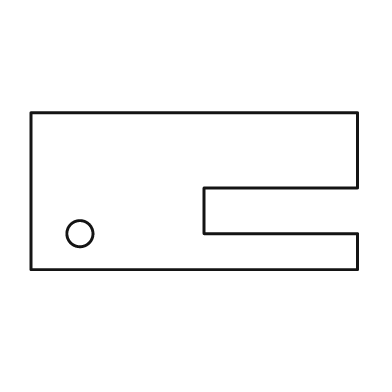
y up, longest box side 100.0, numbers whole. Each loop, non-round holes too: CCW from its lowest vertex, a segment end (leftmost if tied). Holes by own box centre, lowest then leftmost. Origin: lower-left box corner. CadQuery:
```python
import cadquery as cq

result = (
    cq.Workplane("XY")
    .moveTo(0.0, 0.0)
    .lineTo(100.0, 0.0)
    .lineTo(100.0, 11.0)
    .lineTo(53.0, 11.0)
    .lineTo(53.0, 25.0)
    .lineTo(100.0, 25.0)
    .lineTo(100.0, 48.0)
    .lineTo(0.0, 48.0)
    .close()
    .moveTo(15.0, 11.0)
    .circle(4.0)
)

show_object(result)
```